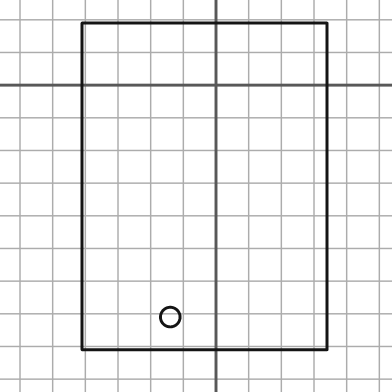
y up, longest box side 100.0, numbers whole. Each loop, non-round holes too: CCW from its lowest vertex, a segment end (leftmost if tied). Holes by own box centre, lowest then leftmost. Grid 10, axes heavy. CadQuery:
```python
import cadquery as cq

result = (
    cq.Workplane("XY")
    .moveTo(-41.0, -81.0)
    .lineTo(34.0, -81.0)
    .lineTo(34.0, 19.0)
    .lineTo(-41.0, 19.0)
    .close()
    .moveTo(-14.0, -71.0)
    .circle(3.0)
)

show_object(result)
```